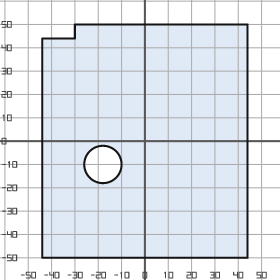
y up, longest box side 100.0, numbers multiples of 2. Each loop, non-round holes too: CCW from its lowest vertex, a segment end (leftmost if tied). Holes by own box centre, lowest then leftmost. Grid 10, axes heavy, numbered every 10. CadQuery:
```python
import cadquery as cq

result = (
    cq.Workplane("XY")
    .moveTo(-44.0, -50.0)
    .lineTo(44.0, -50.0)
    .lineTo(44.0, 50.0)
    .lineTo(-30.0, 50.0)
    .lineTo(-30.0, 44.0)
    .lineTo(-44.0, 44.0)
    .close()
    .moveTo(-18.0, -10.0)
    .circle(8.0)
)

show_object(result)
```